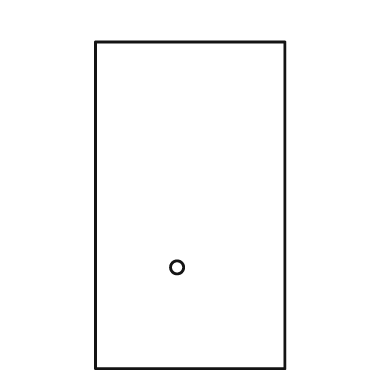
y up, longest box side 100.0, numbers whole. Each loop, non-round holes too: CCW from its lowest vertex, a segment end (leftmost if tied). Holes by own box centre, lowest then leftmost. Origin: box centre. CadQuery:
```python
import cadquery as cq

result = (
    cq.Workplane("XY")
    .moveTo(-29.0, -50.0)
    .lineTo(29.0, -50.0)
    .lineTo(29.0, 50.0)
    .lineTo(-29.0, 50.0)
    .close()
    .moveTo(-4.0, -19.0)
    .circle(2.0)
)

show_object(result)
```